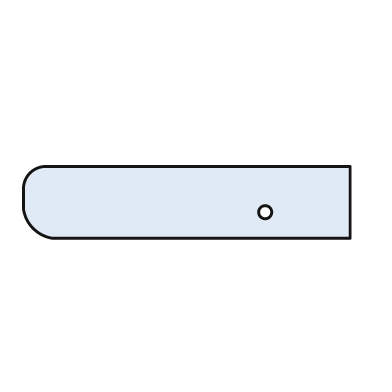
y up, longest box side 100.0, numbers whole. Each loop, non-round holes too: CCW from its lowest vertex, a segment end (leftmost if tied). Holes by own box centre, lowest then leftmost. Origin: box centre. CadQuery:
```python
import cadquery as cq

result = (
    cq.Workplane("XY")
    .moveTo(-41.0, -11.0)
    .lineTo(50.0, -11.0)
    .lineTo(50.0, 11.0)
    .lineTo(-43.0, 11.0)
    .threePointArc((-48.0, 9.0), (-50.0, 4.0))
    .lineTo(-50.0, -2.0)
    .threePointArc((-47.0, -8.0), (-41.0, -11.0))
    .close()
    .moveTo(24.0, -3.0)
    .circle(2.0)
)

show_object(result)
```